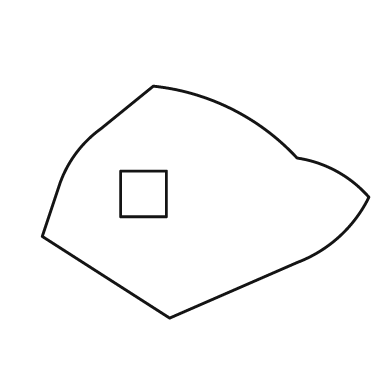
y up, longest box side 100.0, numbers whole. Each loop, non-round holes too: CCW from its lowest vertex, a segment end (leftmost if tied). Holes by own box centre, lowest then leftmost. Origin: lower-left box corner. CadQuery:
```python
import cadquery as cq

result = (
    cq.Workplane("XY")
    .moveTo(39.0, 0.0)
    .lineTo(78.0, 17.0)
    .threePointArc((91.0, 25.0), (100.0, 37.0))
    .threePointArc((90.0, 45.0), (78.0, 49.0))
    .threePointArc((58.0, 64.0), (34.0, 71.0))
    .lineTo(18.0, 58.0)
    .threePointArc((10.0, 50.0), (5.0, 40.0))
    .lineTo(0.0, 25.0)
    .close()
    .moveTo(24.0, 31.0)
    .lineTo(38.0, 31.0)
    .lineTo(38.0, 45.0)
    .lineTo(24.0, 45.0)
    .close()
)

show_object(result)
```